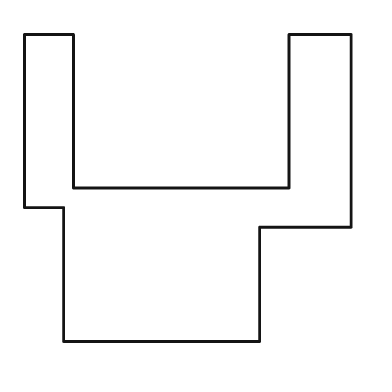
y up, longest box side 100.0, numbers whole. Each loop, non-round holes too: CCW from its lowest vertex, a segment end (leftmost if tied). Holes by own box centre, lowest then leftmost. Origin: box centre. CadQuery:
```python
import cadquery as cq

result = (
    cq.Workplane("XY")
    .moveTo(-38.0, -47.0)
    .lineTo(22.0, -47.0)
    .lineTo(22.0, -12.0)
    .lineTo(50.0, -12.0)
    .lineTo(50.0, 47.0)
    .lineTo(31.0, 47.0)
    .lineTo(31.0, 0.0)
    .lineTo(-35.0, 0.0)
    .lineTo(-35.0, 47.0)
    .lineTo(-50.0, 47.0)
    .lineTo(-50.0, -6.0)
    .lineTo(-38.0, -6.0)
    .close()
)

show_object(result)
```